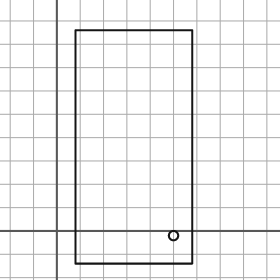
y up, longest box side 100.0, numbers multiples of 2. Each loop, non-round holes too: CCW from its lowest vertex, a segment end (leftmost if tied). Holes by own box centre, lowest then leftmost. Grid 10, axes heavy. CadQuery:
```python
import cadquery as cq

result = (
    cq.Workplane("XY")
    .moveTo(8.0, -14.0)
    .lineTo(58.0, -14.0)
    .lineTo(58.0, 86.0)
    .lineTo(8.0, 86.0)
    .close()
    .moveTo(50.0, -2.0)
    .circle(2.0)
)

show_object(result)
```